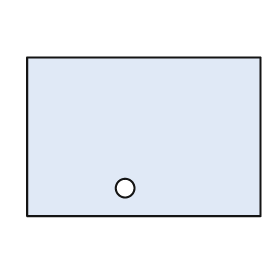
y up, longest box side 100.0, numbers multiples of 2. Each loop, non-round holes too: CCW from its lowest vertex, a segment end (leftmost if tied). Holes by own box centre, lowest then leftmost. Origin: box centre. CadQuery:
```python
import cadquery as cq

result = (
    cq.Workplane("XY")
    .moveTo(-50.0, -34.0)
    .lineTo(50.0, -34.0)
    .lineTo(50.0, 34.0)
    .lineTo(-50.0, 34.0)
    .close()
    .moveTo(-8.0, -22.0)
    .circle(4.0)
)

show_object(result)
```